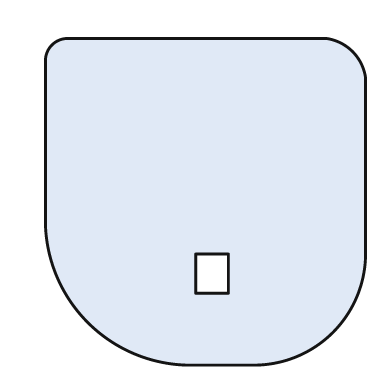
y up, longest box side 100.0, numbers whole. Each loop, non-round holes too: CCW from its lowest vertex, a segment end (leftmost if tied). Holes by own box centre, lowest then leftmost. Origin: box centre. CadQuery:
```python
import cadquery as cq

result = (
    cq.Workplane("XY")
    .moveTo(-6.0, -50.0)
    .lineTo(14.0, -50.0)
    .threePointArc((39.0, -40.0), (49.0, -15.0))
    .lineTo(49.0, 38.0)
    .threePointArc((45.0, 46.0), (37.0, 50.0))
    .lineTo(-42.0, 50.0)
    .threePointArc((-47.0, 48.0), (-49.0, 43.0))
    .lineTo(-49.0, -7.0)
    .threePointArc((-36.0, -37.0), (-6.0, -50.0))
    .close()
    .moveTo(-3.0, -28.0)
    .lineTo(7.0, -28.0)
    .lineTo(7.0, -16.0)
    .lineTo(-3.0, -16.0)
    .close()
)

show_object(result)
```